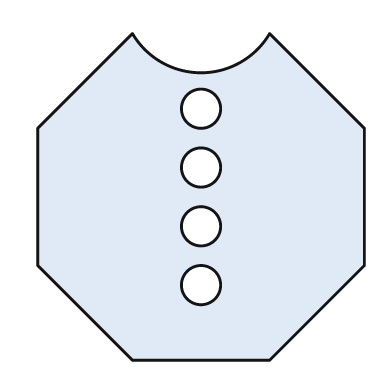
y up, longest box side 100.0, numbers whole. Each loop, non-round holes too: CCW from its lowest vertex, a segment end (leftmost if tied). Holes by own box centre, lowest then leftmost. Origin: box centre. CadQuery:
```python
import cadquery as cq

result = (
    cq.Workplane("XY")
    .moveTo(-21.0, -50.0)
    .lineTo(21.0, -50.0)
    .lineTo(50.0, -21.0)
    .lineTo(50.0, 21.0)
    .lineTo(21.0, 50.0)
    .threePointArc((0.0, 38.0), (-21.0, 50.0))
    .lineTo(-50.0, 21.0)
    .lineTo(-50.0, -21.0)
    .close()
    .moveTo(0.0, -27.0)
    .circle(6.0)
    .moveTo(0.0, -9.0)
    .circle(6.0)
    .moveTo(0.0, 9.0)
    .circle(6.0)
    .moveTo(0.0, 27.0)
    .circle(6.0)
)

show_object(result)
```